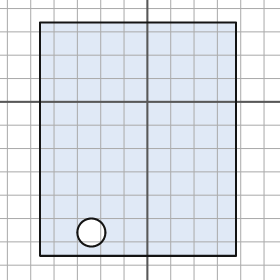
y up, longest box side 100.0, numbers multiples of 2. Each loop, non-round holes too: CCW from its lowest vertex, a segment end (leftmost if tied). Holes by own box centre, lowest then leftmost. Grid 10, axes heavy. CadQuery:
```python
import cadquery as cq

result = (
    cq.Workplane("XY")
    .moveTo(-46.0, -66.0)
    .lineTo(38.0, -66.0)
    .lineTo(38.0, 34.0)
    .lineTo(-46.0, 34.0)
    .close()
    .moveTo(-24.0, -56.0)
    .circle(6.0)
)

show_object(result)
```